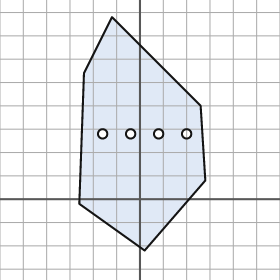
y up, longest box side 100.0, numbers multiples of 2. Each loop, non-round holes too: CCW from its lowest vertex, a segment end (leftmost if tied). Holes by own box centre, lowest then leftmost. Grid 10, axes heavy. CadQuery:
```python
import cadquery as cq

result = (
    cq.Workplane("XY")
    .moveTo(2.0, -22.0)
    .lineTo(28.0, 8.0)
    .lineTo(26.0, 40.0)
    .lineTo(-12.0, 78.0)
    .lineTo(-24.0, 54.0)
    .lineTo(-26.0, -2.0)
    .close()
    .moveTo(-16.0, 28.0)
    .circle(2.0)
    .moveTo(-4.0, 28.0)
    .circle(2.0)
    .moveTo(8.0, 28.0)
    .circle(2.0)
    .moveTo(20.0, 28.0)
    .circle(2.0)
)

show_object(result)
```